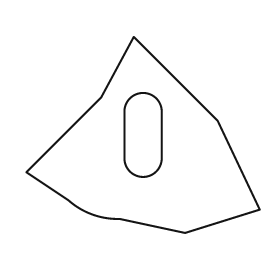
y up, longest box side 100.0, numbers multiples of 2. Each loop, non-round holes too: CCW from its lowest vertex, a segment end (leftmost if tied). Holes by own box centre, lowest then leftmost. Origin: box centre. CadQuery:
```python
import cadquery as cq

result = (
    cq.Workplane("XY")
    .moveTo(18.0, -42.0)
    .lineTo(50.0, -32.0)
    .lineTo(32.0, 6.0)
    .lineTo(-4.0, 42.0)
    .lineTo(-18.0, 16.0)
    .lineTo(-50.0, -16.0)
    .lineTo(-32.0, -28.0)
    .threePointArc((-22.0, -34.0), (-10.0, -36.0))
    .close()
    .moveTo(-8.0, -10.0)
    .threePointArc((0.0, -18.0), (8.0, -10.0))
    .lineTo(8.0, 10.0)
    .threePointArc((0.0, 18.0), (-8.0, 10.0))
    .close()
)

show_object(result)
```